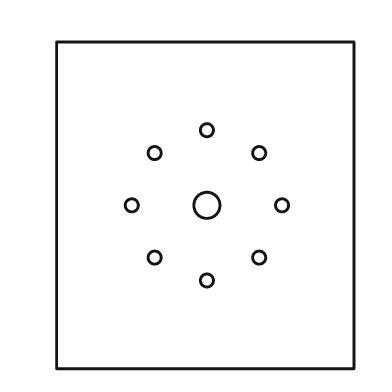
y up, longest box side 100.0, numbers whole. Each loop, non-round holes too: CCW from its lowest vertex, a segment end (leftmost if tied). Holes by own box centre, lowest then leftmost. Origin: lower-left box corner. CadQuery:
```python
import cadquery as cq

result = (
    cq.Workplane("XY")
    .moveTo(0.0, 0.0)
    .lineTo(91.0, 0.0)
    .lineTo(91.0, 100.0)
    .lineTo(0.0, 100.0)
    .close()
    .moveTo(46.0, 27.0)
    .circle(2.0)
    .moveTo(30.0, 34.0)
    .circle(2.0)
    .moveTo(62.0, 34.0)
    .circle(2.0)
    .moveTo(23.0, 50.0)
    .circle(2.0)
    .moveTo(46.0, 50.0)
    .circle(4.0)
    .moveTo(69.0, 50.0)
    .circle(2.0)
    .moveTo(30.0, 66.0)
    .circle(2.0)
    .moveTo(62.0, 66.0)
    .circle(2.0)
    .moveTo(46.0, 73.0)
    .circle(2.0)
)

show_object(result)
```